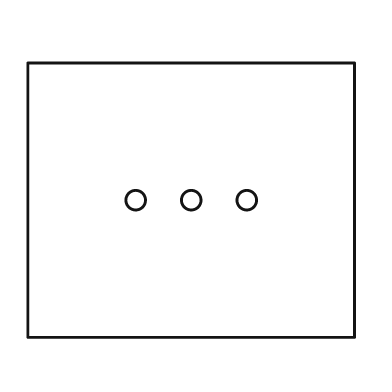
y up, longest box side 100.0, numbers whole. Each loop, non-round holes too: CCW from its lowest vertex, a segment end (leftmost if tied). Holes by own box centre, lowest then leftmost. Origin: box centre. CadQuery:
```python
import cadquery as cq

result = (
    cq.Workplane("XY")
    .moveTo(-50.0, -42.0)
    .lineTo(50.0, -42.0)
    .lineTo(50.0, 42.0)
    .lineTo(-50.0, 42.0)
    .close()
    .moveTo(-17.0, 0.0)
    .circle(3.0)
    .moveTo(0.0, 0.0)
    .circle(3.0)
    .moveTo(17.0, 0.0)
    .circle(3.0)
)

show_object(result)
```